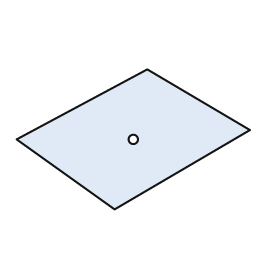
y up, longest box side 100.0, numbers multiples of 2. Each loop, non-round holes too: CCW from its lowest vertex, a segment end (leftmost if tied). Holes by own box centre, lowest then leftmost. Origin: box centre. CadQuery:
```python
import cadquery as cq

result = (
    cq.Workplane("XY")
    .moveTo(-8.0, -30.0)
    .lineTo(50.0, 4.0)
    .lineTo(6.0, 30.0)
    .lineTo(-50.0, 0.0)
    .close()
    .moveTo(0.0, 0.0)
    .circle(2.0)
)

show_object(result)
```